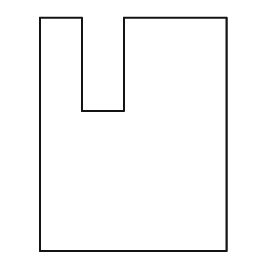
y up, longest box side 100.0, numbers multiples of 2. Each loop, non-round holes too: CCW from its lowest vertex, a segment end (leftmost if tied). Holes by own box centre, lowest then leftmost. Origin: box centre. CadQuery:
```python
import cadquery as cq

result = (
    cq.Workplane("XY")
    .moveTo(-40.0, -50.0)
    .lineTo(40.0, -50.0)
    .lineTo(40.0, 50.0)
    .lineTo(-4.0, 50.0)
    .lineTo(-4.0, 10.0)
    .lineTo(-22.0, 10.0)
    .lineTo(-22.0, 50.0)
    .lineTo(-40.0, 50.0)
    .close()
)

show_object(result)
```